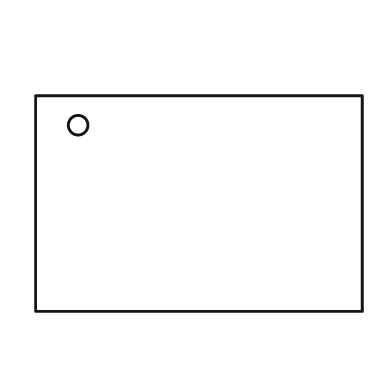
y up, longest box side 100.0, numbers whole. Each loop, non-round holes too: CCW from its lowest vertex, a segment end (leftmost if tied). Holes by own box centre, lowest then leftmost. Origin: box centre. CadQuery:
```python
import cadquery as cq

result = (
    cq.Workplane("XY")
    .moveTo(-50.0, -33.0)
    .lineTo(50.0, -33.0)
    .lineTo(50.0, 33.0)
    .lineTo(-50.0, 33.0)
    .close()
    .moveTo(-37.0, 24.0)
    .circle(3.0)
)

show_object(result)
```